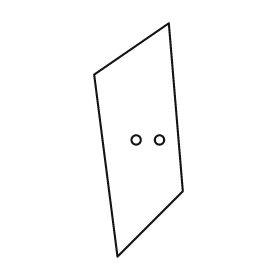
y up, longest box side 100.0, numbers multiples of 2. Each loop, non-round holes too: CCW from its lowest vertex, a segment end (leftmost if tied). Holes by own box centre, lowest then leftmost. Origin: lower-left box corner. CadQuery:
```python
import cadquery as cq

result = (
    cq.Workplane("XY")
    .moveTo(10.0, 0.0)
    .lineTo(38.0, 28.0)
    .lineTo(32.0, 100.0)
    .lineTo(0.0, 78.0)
    .close()
    .moveTo(18.0, 50.0)
    .circle(2.0)
    .moveTo(28.0, 50.0)
    .circle(2.0)
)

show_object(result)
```